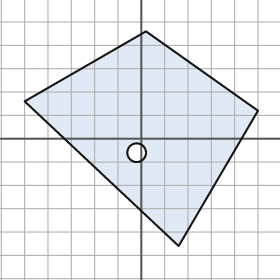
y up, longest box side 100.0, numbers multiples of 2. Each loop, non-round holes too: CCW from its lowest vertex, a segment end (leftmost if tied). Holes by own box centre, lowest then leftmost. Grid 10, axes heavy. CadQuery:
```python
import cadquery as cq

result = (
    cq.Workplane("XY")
    .moveTo(16.0, -46.0)
    .lineTo(50.0, 12.0)
    .lineTo(2.0, 46.0)
    .lineTo(-50.0, 16.0)
    .close()
    .moveTo(-2.0, -6.0)
    .circle(4.0)
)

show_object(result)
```